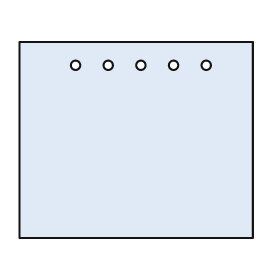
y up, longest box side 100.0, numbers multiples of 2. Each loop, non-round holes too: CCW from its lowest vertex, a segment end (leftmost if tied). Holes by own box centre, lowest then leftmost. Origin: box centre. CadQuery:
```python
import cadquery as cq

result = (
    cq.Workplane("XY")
    .moveTo(-50.0, -42.0)
    .lineTo(50.0, -42.0)
    .lineTo(50.0, 42.0)
    .lineTo(-50.0, 42.0)
    .close()
    .moveTo(-26.0, 32.0)
    .circle(2.0)
    .moveTo(-12.0, 32.0)
    .circle(2.0)
    .moveTo(2.0, 32.0)
    .circle(2.0)
    .moveTo(16.0, 32.0)
    .circle(2.0)
    .moveTo(30.0, 32.0)
    .circle(2.0)
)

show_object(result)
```